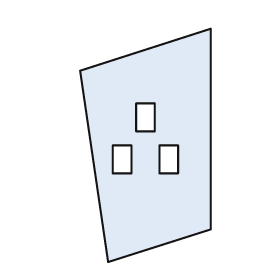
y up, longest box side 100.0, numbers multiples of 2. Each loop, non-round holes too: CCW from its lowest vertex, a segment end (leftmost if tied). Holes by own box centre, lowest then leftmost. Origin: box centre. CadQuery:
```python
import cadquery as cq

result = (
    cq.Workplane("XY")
    .moveTo(-16.0, -50.0)
    .lineTo(28.0, -36.0)
    .lineTo(28.0, 50.0)
    .lineTo(-28.0, 32.0)
    .close()
    .moveTo(-14.0, -12.0)
    .lineTo(-6.0, -12.0)
    .lineTo(-6.0, 0.0)
    .lineTo(-14.0, 0.0)
    .close()
    .moveTo(6.0, -12.0)
    .lineTo(14.0, -12.0)
    .lineTo(14.0, 0.0)
    .lineTo(6.0, 0.0)
    .close()
    .moveTo(-4.0, 6.0)
    .lineTo(4.0, 6.0)
    .lineTo(4.0, 18.0)
    .lineTo(-4.0, 18.0)
    .close()
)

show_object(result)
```